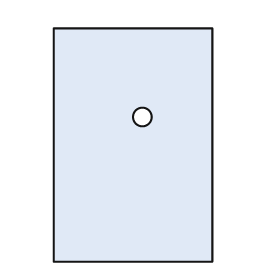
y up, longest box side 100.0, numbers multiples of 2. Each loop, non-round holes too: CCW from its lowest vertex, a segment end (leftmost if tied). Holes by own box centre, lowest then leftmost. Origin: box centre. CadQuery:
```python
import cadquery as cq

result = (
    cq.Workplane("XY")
    .moveTo(-34.0, -50.0)
    .lineTo(34.0, -50.0)
    .lineTo(34.0, 50.0)
    .lineTo(-34.0, 50.0)
    .close()
    .moveTo(4.0, 12.0)
    .circle(4.0)
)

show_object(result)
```